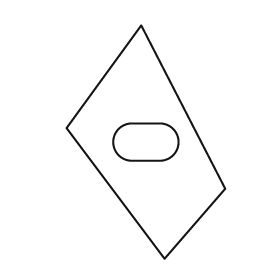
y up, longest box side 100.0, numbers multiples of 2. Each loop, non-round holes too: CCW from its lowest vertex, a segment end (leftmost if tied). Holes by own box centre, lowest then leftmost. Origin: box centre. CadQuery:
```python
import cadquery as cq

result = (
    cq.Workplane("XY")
    .moveTo(8.0, -50.0)
    .lineTo(34.0, -20.0)
    .lineTo(-2.0, 50.0)
    .lineTo(-34.0, 6.0)
    .close()
    .moveTo(-6.0, -8.0)
    .lineTo(6.0, -8.0)
    .threePointArc((14.0, 0.0), (6.0, 8.0))
    .lineTo(-6.0, 8.0)
    .threePointArc((-14.0, 0.0), (-6.0, -8.0))
    .close()
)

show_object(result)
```